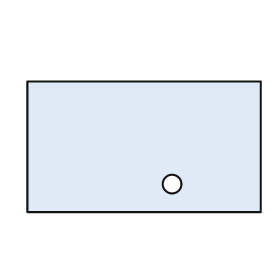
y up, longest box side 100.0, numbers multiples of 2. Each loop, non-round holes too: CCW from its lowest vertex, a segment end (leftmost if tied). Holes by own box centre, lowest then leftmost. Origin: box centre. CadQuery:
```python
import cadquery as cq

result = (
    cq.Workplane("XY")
    .moveTo(-50.0, -28.0)
    .lineTo(50.0, -28.0)
    .lineTo(50.0, 28.0)
    .lineTo(-50.0, 28.0)
    .close()
    .moveTo(12.0, -16.0)
    .circle(4.0)
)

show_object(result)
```